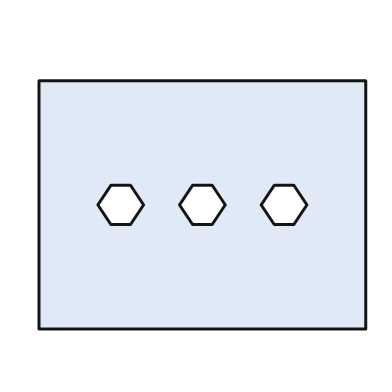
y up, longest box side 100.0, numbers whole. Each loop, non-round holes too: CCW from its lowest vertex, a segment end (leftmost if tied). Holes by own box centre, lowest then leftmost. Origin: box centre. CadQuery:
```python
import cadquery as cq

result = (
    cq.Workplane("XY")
    .moveTo(-50.0, -38.0)
    .lineTo(50.0, -38.0)
    .lineTo(50.0, 38.0)
    .lineTo(-50.0, 38.0)
    .close()
    .moveTo(-28.0, -6.0)
    .lineTo(-22.0, -6.0)
    .lineTo(-18.0, 0.0)
    .lineTo(-22.0, 6.0)
    .lineTo(-28.0, 6.0)
    .lineTo(-32.0, 0.0)
    .close()
    .moveTo(-3.0, -6.0)
    .lineTo(3.0, -6.0)
    .lineTo(7.0, 0.0)
    .lineTo(3.0, 6.0)
    .lineTo(-3.0, 6.0)
    .lineTo(-7.0, 0.0)
    .close()
    .moveTo(22.0, -6.0)
    .lineTo(28.0, -6.0)
    .lineTo(32.0, 0.0)
    .lineTo(28.0, 6.0)
    .lineTo(22.0, 6.0)
    .lineTo(18.0, 0.0)
    .close()
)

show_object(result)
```